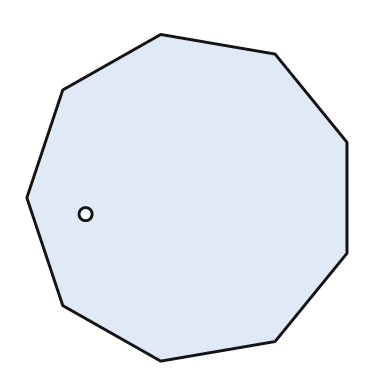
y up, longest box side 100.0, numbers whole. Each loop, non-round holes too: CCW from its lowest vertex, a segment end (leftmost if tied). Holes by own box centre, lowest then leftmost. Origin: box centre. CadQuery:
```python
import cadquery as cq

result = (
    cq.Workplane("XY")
    .moveTo(-8.0, -50.0)
    .lineTo(27.0, -44.0)
    .lineTo(49.0, -17.0)
    .lineTo(49.0, 17.0)
    .lineTo(27.0, 44.0)
    .lineTo(-8.0, 50.0)
    .lineTo(-38.0, 33.0)
    .lineTo(-49.0, 0.0)
    .lineTo(-38.0, -33.0)
    .close()
    .moveTo(-31.0, -5.0)
    .circle(2.0)
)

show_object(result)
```